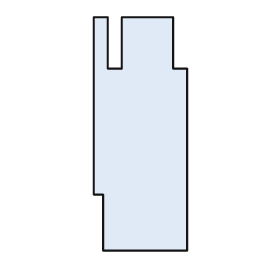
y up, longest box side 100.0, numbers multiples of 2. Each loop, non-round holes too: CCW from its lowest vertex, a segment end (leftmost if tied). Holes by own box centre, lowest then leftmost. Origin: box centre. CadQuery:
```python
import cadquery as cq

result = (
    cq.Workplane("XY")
    .moveTo(-16.0, -50.0)
    .lineTo(20.0, -50.0)
    .lineTo(20.0, 28.0)
    .lineTo(14.0, 28.0)
    .lineTo(14.0, 50.0)
    .lineTo(-8.0, 50.0)
    .lineTo(-8.0, 28.0)
    .lineTo(-14.0, 28.0)
    .lineTo(-14.0, 50.0)
    .lineTo(-20.0, 50.0)
    .lineTo(-20.0, -26.0)
    .lineTo(-16.0, -26.0)
    .close()
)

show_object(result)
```